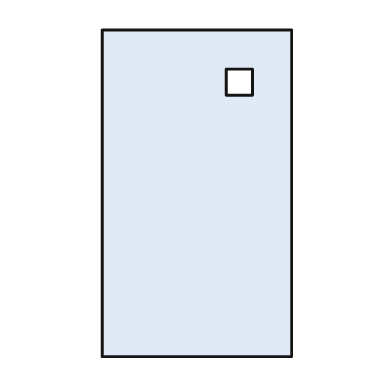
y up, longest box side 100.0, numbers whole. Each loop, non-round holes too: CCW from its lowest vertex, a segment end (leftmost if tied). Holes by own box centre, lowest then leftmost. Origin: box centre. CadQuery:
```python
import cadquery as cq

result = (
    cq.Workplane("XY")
    .moveTo(-29.0, -50.0)
    .lineTo(29.0, -50.0)
    .lineTo(29.0, 50.0)
    .lineTo(-29.0, 50.0)
    .close()
    .moveTo(9.0, 30.0)
    .lineTo(17.0, 30.0)
    .lineTo(17.0, 38.0)
    .lineTo(9.0, 38.0)
    .close()
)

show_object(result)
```